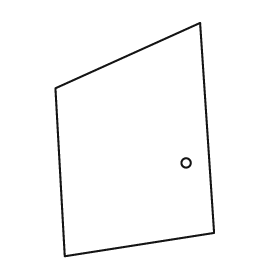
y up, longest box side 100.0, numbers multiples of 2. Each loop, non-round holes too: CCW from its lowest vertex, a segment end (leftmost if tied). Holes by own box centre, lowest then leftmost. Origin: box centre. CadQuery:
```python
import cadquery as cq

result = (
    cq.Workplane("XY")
    .moveTo(-30.0, -50.0)
    .lineTo(34.0, -40.0)
    .lineTo(28.0, 50.0)
    .lineTo(-34.0, 22.0)
    .close()
    .moveTo(22.0, -10.0)
    .circle(2.0)
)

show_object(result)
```